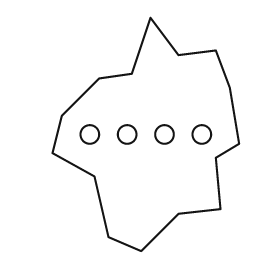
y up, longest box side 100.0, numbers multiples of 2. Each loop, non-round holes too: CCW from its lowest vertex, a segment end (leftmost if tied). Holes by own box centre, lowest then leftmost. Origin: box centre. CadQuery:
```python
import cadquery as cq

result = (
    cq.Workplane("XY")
    .moveTo(-2.0, -50.0)
    .lineTo(14.0, -34.0)
    .lineTo(32.0, -32.0)
    .lineTo(30.0, -10.0)
    .lineTo(40.0, -4.0)
    .lineTo(36.0, 20.0)
    .lineTo(30.0, 36.0)
    .lineTo(14.0, 34.0)
    .lineTo(2.0, 50.0)
    .lineTo(-6.0, 26.0)
    .lineTo(-20.0, 24.0)
    .lineTo(-36.0, 8.0)
    .lineTo(-40.0, -8.0)
    .lineTo(-22.0, -18.0)
    .lineTo(-16.0, -44.0)
    .close()
    .moveTo(-24.0, 0.0)
    .circle(4.0)
    .moveTo(-8.0, 0.0)
    .circle(4.0)
    .moveTo(8.0, 0.0)
    .circle(4.0)
    .moveTo(24.0, 0.0)
    .circle(4.0)
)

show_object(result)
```